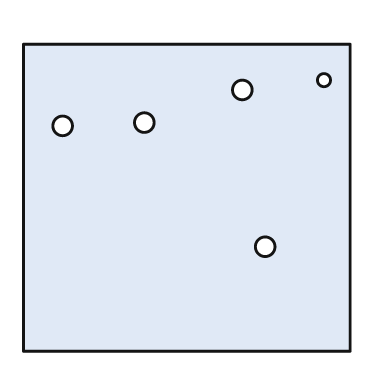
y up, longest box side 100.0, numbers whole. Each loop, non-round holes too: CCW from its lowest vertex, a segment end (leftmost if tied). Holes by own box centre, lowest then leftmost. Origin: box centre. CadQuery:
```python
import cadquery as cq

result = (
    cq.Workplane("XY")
    .moveTo(-50.0, -47.0)
    .lineTo(50.0, -47.0)
    .lineTo(50.0, 47.0)
    .lineTo(-50.0, 47.0)
    .close()
    .moveTo(24.0, -15.0)
    .circle(3.0)
    .moveTo(-38.0, 22.0)
    .circle(3.0)
    .moveTo(-13.0, 23.0)
    .circle(3.0)
    .moveTo(17.0, 33.0)
    .circle(3.0)
    .moveTo(42.0, 36.0)
    .circle(2.0)
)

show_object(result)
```